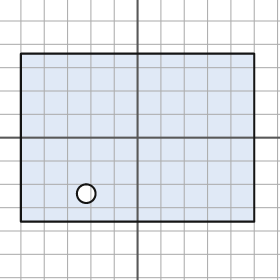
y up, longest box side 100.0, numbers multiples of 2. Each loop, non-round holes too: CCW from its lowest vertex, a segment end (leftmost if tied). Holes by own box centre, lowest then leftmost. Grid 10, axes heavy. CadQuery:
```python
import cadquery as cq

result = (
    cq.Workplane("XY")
    .moveTo(-50.0, -36.0)
    .lineTo(50.0, -36.0)
    .lineTo(50.0, 36.0)
    .lineTo(-50.0, 36.0)
    .close()
    .moveTo(-22.0, -24.0)
    .circle(4.0)
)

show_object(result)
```